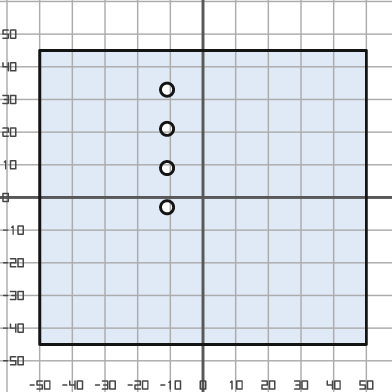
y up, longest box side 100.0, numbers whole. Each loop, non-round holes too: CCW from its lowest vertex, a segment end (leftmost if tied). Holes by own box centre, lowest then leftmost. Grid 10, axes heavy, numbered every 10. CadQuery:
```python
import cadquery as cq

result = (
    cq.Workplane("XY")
    .moveTo(-50.0, -45.0)
    .lineTo(50.0, -45.0)
    .lineTo(50.0, 45.0)
    .lineTo(-50.0, 45.0)
    .close()
    .moveTo(-11.0, -3.0)
    .circle(2.0)
    .moveTo(-11.0, 9.0)
    .circle(2.0)
    .moveTo(-11.0, 21.0)
    .circle(2.0)
    .moveTo(-11.0, 33.0)
    .circle(2.0)
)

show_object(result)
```